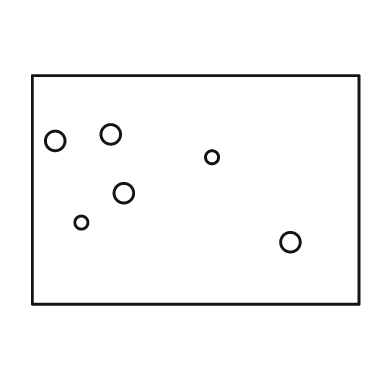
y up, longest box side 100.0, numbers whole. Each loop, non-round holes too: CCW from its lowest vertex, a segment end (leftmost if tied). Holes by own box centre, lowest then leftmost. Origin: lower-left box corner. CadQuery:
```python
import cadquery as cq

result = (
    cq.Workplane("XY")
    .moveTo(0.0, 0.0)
    .lineTo(100.0, 0.0)
    .lineTo(100.0, 70.0)
    .lineTo(0.0, 70.0)
    .close()
    .moveTo(79.0, 19.0)
    .circle(3.0)
    .moveTo(15.0, 25.0)
    .circle(2.0)
    .moveTo(28.0, 34.0)
    .circle(3.0)
    .moveTo(55.0, 45.0)
    .circle(2.0)
    .moveTo(7.0, 50.0)
    .circle(3.0)
    .moveTo(24.0, 52.0)
    .circle(3.0)
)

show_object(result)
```